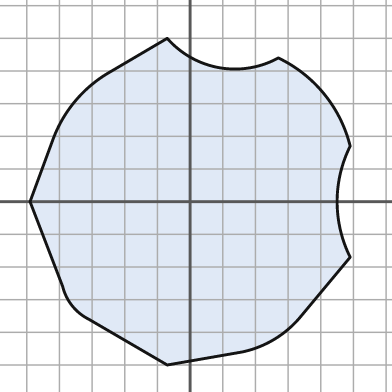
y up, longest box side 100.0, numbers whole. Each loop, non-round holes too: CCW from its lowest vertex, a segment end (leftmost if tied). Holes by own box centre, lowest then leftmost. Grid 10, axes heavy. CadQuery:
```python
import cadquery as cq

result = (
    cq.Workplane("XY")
    .moveTo(-7.0, -50.0)
    .lineTo(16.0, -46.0)
    .threePointArc((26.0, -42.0), (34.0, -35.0))
    .lineTo(49.0, -17.0)
    .threePointArc((45.0, 0.0), (49.0, 17.0))
    .threePointArc((41.0, 33.0), (27.0, 44.0))
    .threePointArc((9.0, 41.0), (-7.0, 50.0))
    .lineTo(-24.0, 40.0)
    .threePointArc((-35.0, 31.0), (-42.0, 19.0))
    .lineTo(-49.0, 0.0)
    .lineTo(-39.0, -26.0)
    .threePointArc((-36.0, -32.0), (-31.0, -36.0))
    .close()
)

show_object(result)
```